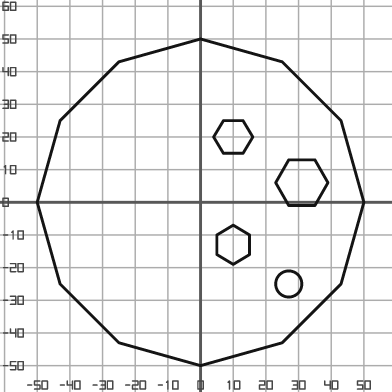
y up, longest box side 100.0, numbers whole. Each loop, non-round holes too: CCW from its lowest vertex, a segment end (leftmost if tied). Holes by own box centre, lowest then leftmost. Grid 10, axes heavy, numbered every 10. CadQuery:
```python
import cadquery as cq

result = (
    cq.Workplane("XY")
    .moveTo(0.0, -50.0)
    .lineTo(25.0, -43.0)
    .lineTo(43.0, -25.0)
    .lineTo(50.0, 0.0)
    .lineTo(43.0, 25.0)
    .lineTo(25.0, 43.0)
    .lineTo(0.0, 50.0)
    .lineTo(-25.0, 43.0)
    .lineTo(-43.0, 25.0)
    .lineTo(-50.0, 0.0)
    .lineTo(-43.0, -25.0)
    .lineTo(-25.0, -43.0)
    .close()
    .moveTo(27.0, -25.0)
    .circle(4.0)
    .moveTo(10.0, -19.0)
    .lineTo(15.0, -16.0)
    .lineTo(15.0, -10.0)
    .lineTo(10.0, -7.0)
    .lineTo(5.0, -10.0)
    .lineTo(5.0, -16.0)
    .close()
    .moveTo(27.0, -1.0)
    .lineTo(35.0, -1.0)
    .lineTo(39.0, 6.0)
    .lineTo(35.0, 13.0)
    .lineTo(27.0, 13.0)
    .lineTo(23.0, 6.0)
    .close()
    .moveTo(7.0, 15.0)
    .lineTo(13.0, 15.0)
    .lineTo(16.0, 20.0)
    .lineTo(13.0, 25.0)
    .lineTo(7.0, 25.0)
    .lineTo(4.0, 20.0)
    .close()
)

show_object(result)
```